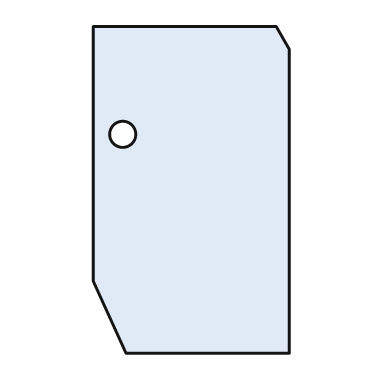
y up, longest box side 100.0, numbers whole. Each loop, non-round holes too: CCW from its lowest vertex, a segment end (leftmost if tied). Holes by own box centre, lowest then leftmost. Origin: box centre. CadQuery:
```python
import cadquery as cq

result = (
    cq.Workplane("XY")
    .moveTo(-20.0, -50.0)
    .lineTo(30.0, -50.0)
    .lineTo(30.0, 43.0)
    .lineTo(26.0, 50.0)
    .lineTo(-30.0, 50.0)
    .lineTo(-30.0, -28.0)
    .close()
    .moveTo(-21.0, 17.0)
    .circle(4.0)
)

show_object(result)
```